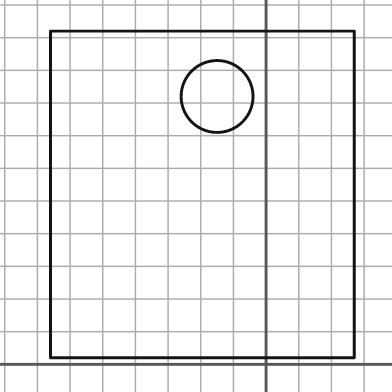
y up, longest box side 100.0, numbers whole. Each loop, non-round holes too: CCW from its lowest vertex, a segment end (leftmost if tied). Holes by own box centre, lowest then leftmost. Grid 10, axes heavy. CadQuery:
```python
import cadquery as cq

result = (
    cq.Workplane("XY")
    .moveTo(-66.0, 2.0)
    .lineTo(27.0, 2.0)
    .lineTo(27.0, 102.0)
    .lineTo(-66.0, 102.0)
    .close()
    .moveTo(-15.0, 82.0)
    .circle(11.0)
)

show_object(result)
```